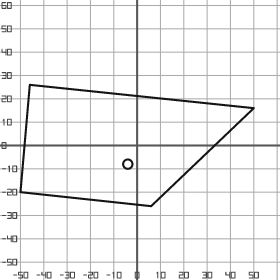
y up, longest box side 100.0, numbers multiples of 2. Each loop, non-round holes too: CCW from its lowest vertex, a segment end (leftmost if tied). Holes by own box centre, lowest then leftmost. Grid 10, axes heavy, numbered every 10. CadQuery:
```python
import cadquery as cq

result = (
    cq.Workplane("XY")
    .moveTo(6.0, -26.0)
    .lineTo(50.0, 16.0)
    .lineTo(-46.0, 26.0)
    .lineTo(-50.0, -20.0)
    .close()
    .moveTo(-4.0, -8.0)
    .circle(2.0)
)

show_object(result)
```